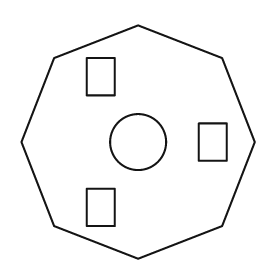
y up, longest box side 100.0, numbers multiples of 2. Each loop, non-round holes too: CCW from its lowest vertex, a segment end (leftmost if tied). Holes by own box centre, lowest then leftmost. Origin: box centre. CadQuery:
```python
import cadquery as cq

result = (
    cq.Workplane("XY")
    .moveTo(0.0, -50.0)
    .lineTo(36.0, -36.0)
    .lineTo(50.0, 0.0)
    .lineTo(36.0, 36.0)
    .lineTo(0.0, 50.0)
    .lineTo(-36.0, 36.0)
    .lineTo(-50.0, 0.0)
    .lineTo(-36.0, -36.0)
    .close()
    .moveTo(-22.0, -36.0)
    .lineTo(-10.0, -36.0)
    .lineTo(-10.0, -20.0)
    .lineTo(-22.0, -20.0)
    .close()
    .moveTo(0.0, 0.0)
    .circle(12.0)
    .moveTo(26.0, -8.0)
    .lineTo(38.0, -8.0)
    .lineTo(38.0, 8.0)
    .lineTo(26.0, 8.0)
    .close()
    .moveTo(-22.0, 20.0)
    .lineTo(-10.0, 20.0)
    .lineTo(-10.0, 36.0)
    .lineTo(-22.0, 36.0)
    .close()
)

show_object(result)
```